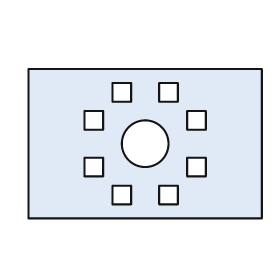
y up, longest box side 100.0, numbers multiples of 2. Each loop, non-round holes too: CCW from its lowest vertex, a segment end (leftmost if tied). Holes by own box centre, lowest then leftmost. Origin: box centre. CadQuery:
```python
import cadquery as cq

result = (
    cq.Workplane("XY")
    .moveTo(-50.0, -32.0)
    .lineTo(50.0, -32.0)
    .lineTo(50.0, 32.0)
    .lineTo(-50.0, 32.0)
    .close()
    .moveTo(-14.0, -26.0)
    .lineTo(-6.0, -26.0)
    .lineTo(-6.0, -18.0)
    .lineTo(-14.0, -18.0)
    .close()
    .moveTo(6.0, -26.0)
    .lineTo(14.0, -26.0)
    .lineTo(14.0, -18.0)
    .lineTo(6.0, -18.0)
    .close()
    .moveTo(-26.0, -14.0)
    .lineTo(-18.0, -14.0)
    .lineTo(-18.0, -6.0)
    .lineTo(-26.0, -6.0)
    .close()
    .moveTo(18.0, -14.0)
    .lineTo(26.0, -14.0)
    .lineTo(26.0, -6.0)
    .lineTo(18.0, -6.0)
    .close()
    .moveTo(0.0, 0.0)
    .circle(10.0)
    .moveTo(-26.0, 6.0)
    .lineTo(-18.0, 6.0)
    .lineTo(-18.0, 14.0)
    .lineTo(-26.0, 14.0)
    .close()
    .moveTo(18.0, 6.0)
    .lineTo(26.0, 6.0)
    .lineTo(26.0, 14.0)
    .lineTo(18.0, 14.0)
    .close()
    .moveTo(-14.0, 18.0)
    .lineTo(-6.0, 18.0)
    .lineTo(-6.0, 26.0)
    .lineTo(-14.0, 26.0)
    .close()
    .moveTo(6.0, 18.0)
    .lineTo(14.0, 18.0)
    .lineTo(14.0, 26.0)
    .lineTo(6.0, 26.0)
    .close()
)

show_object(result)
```